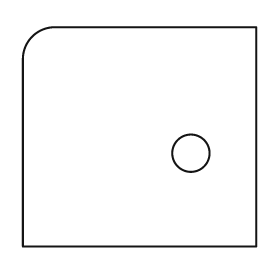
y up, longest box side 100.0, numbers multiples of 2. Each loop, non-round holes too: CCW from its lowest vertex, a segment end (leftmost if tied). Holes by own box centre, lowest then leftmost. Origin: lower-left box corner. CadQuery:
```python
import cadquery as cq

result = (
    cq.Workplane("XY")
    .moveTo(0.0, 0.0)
    .lineTo(100.0, 0.0)
    .lineTo(100.0, 94.0)
    .lineTo(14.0, 94.0)
    .threePointArc((4.0, 90.0), (0.0, 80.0))
    .close()
    .moveTo(72.0, 40.0)
    .circle(8.0)
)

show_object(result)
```